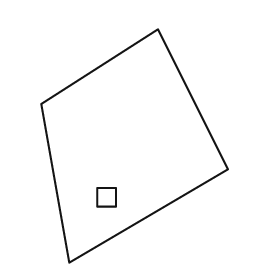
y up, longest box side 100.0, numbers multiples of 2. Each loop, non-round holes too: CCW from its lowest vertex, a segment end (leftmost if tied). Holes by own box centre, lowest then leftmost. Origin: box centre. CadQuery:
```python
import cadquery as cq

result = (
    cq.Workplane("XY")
    .moveTo(-28.0, -50.0)
    .lineTo(40.0, -10.0)
    .lineTo(10.0, 50.0)
    .lineTo(-40.0, 18.0)
    .close()
    .moveTo(-16.0, -26.0)
    .lineTo(-8.0, -26.0)
    .lineTo(-8.0, -18.0)
    .lineTo(-16.0, -18.0)
    .close()
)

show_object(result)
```